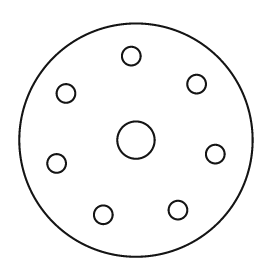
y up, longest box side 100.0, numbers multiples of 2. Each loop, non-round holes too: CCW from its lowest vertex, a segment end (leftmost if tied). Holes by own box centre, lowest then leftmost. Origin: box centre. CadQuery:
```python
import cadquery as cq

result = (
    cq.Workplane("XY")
    .moveTo(0.0, 0.0)
    .circle(50.0)
    .moveTo(-14.0, -32.0)
    .circle(4.0)
    .moveTo(18.0, -30.0)
    .circle(4.0)
    .moveTo(-34.0, -10.0)
    .circle(4.0)
    .moveTo(34.0, -6.0)
    .circle(4.0)
    .moveTo(0.0, 0.0)
    .circle(8.0)
    .moveTo(-30.0, 20.0)
    .circle(4.0)
    .moveTo(26.0, 24.0)
    .circle(4.0)
    .moveTo(-2.0, 36.0)
    .circle(4.0)
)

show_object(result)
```